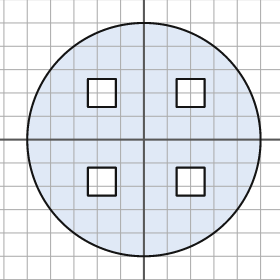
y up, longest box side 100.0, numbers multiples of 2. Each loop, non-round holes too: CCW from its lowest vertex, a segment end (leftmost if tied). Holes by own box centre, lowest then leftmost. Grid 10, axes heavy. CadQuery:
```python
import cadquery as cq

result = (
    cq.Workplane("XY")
    .moveTo(0.0, 0.0)
    .circle(50.0)
    .moveTo(-24.0, -24.0)
    .lineTo(-12.0, -24.0)
    .lineTo(-12.0, -12.0)
    .lineTo(-24.0, -12.0)
    .close()
    .moveTo(14.0, -24.0)
    .lineTo(26.0, -24.0)
    .lineTo(26.0, -12.0)
    .lineTo(14.0, -12.0)
    .close()
    .moveTo(-24.0, 14.0)
    .lineTo(-12.0, 14.0)
    .lineTo(-12.0, 26.0)
    .lineTo(-24.0, 26.0)
    .close()
    .moveTo(14.0, 14.0)
    .lineTo(26.0, 14.0)
    .lineTo(26.0, 26.0)
    .lineTo(14.0, 26.0)
    .close()
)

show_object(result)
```